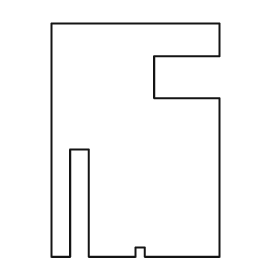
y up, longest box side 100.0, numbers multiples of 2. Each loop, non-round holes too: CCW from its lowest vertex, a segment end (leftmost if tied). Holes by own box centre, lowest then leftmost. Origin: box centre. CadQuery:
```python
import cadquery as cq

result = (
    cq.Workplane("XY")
    .moveTo(-36.0, -50.0)
    .lineTo(-28.0, -50.0)
    .lineTo(-28.0, -4.0)
    .lineTo(-20.0, -4.0)
    .lineTo(-20.0, -50.0)
    .lineTo(0.0, -50.0)
    .lineTo(0.0, -46.0)
    .lineTo(4.0, -46.0)
    .lineTo(4.0, -50.0)
    .lineTo(36.0, -50.0)
    .lineTo(36.0, 18.0)
    .lineTo(8.0, 18.0)
    .lineTo(8.0, 36.0)
    .lineTo(36.0, 36.0)
    .lineTo(36.0, 50.0)
    .lineTo(-36.0, 50.0)
    .close()
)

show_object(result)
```